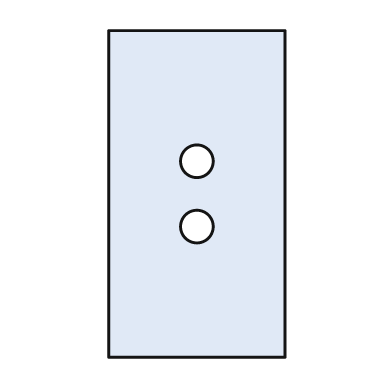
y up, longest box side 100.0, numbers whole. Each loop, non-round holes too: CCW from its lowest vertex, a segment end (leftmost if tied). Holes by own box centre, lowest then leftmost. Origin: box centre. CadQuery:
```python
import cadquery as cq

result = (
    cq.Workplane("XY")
    .moveTo(-27.0, -50.0)
    .lineTo(27.0, -50.0)
    .lineTo(27.0, 50.0)
    .lineTo(-27.0, 50.0)
    .close()
    .moveTo(0.0, -10.0)
    .circle(5.0)
    .moveTo(0.0, 10.0)
    .circle(5.0)
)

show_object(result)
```